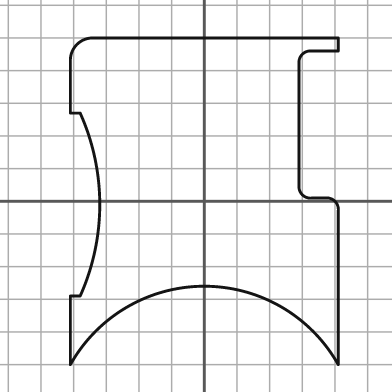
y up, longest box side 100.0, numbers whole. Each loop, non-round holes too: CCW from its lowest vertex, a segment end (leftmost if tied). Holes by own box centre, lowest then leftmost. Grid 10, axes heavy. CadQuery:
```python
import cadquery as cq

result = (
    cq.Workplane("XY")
    .moveTo(-41.0, -50.0)
    .threePointArc((0.0, -26.0), (41.0, -50.0))
    .lineTo(41.0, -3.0)
    .threePointArc((40.0, 0.0), (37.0, 1.0))
    .lineTo(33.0, 1.0)
    .threePointArc((30.0, 2.0), (29.0, 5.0))
    .lineTo(29.0, 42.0)
    .threePointArc((30.0, 45.0), (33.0, 46.0))
    .lineTo(41.0, 46.0)
    .lineTo(41.0, 50.0)
    .lineTo(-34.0, 50.0)
    .threePointArc((-39.0, 48.0), (-41.0, 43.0))
    .lineTo(-41.0, 27.0)
    .lineTo(-38.0, 27.0)
    .threePointArc((-32.0, -1.0), (-38.0, -29.0))
    .lineTo(-41.0, -29.0)
    .close()
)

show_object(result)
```